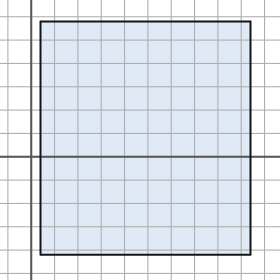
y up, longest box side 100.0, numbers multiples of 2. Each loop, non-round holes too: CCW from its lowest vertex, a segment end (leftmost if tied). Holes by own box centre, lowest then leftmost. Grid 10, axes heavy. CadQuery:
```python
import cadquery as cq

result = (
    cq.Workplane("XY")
    .moveTo(4.0, -42.0)
    .lineTo(94.0, -42.0)
    .lineTo(94.0, 58.0)
    .lineTo(4.0, 58.0)
    .close()
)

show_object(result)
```